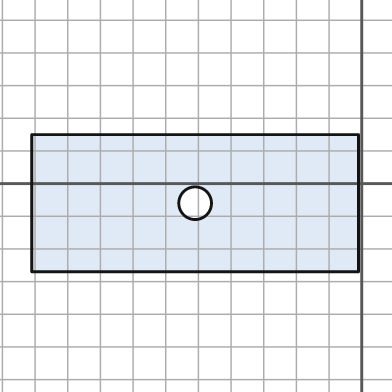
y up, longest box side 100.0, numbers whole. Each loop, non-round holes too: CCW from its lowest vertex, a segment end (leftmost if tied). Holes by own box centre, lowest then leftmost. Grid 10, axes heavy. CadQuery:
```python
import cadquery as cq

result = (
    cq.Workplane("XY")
    .moveTo(-101.0, -27.0)
    .lineTo(-1.0, -27.0)
    .lineTo(-1.0, 15.0)
    .lineTo(-101.0, 15.0)
    .close()
    .moveTo(-51.0, -6.0)
    .circle(5.0)
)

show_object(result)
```